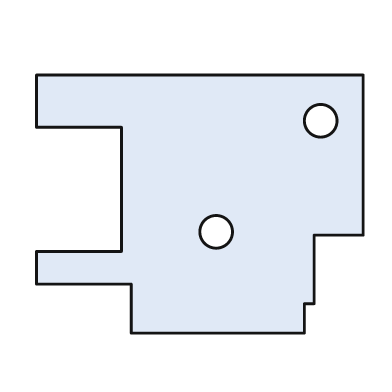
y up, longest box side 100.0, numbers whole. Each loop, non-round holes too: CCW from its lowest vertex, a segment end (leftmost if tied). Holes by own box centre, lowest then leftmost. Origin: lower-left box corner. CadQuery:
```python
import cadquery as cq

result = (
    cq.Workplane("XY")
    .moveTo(29.0, 0.0)
    .lineTo(82.0, 0.0)
    .lineTo(82.0, 9.0)
    .lineTo(85.0, 9.0)
    .lineTo(85.0, 30.0)
    .lineTo(100.0, 30.0)
    .lineTo(100.0, 79.0)
    .lineTo(0.0, 79.0)
    .lineTo(0.0, 63.0)
    .lineTo(26.0, 63.0)
    .lineTo(26.0, 25.0)
    .lineTo(0.0, 25.0)
    .lineTo(0.0, 15.0)
    .lineTo(29.0, 15.0)
    .close()
    .moveTo(55.0, 31.0)
    .circle(5.0)
    .moveTo(87.0, 65.0)
    .circle(5.0)
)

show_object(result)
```